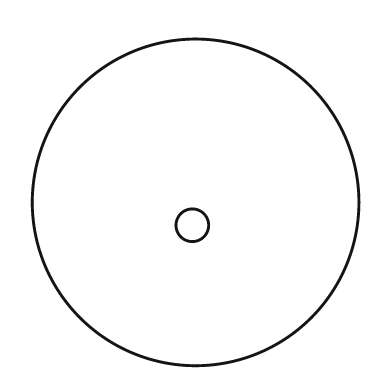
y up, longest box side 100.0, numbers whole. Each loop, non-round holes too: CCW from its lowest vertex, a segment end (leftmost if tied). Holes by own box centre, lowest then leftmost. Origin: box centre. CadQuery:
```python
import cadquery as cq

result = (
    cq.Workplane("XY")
    .moveTo(0.0, 0.0)
    .circle(50.0)
    .moveTo(-1.0, -7.0)
    .circle(5.0)
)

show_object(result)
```